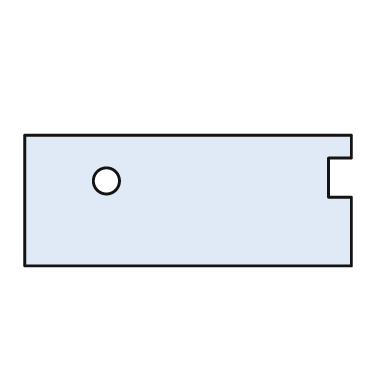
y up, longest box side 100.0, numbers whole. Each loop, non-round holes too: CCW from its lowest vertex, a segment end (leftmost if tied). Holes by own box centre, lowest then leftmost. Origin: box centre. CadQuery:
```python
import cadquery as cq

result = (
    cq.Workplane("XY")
    .moveTo(-50.0, -20.0)
    .lineTo(50.0, -20.0)
    .lineTo(50.0, 1.0)
    .lineTo(43.0, 1.0)
    .lineTo(43.0, 13.0)
    .lineTo(50.0, 13.0)
    .lineTo(50.0, 20.0)
    .lineTo(-50.0, 20.0)
    .close()
    .moveTo(-25.0, 6.0)
    .circle(4.0)
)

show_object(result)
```